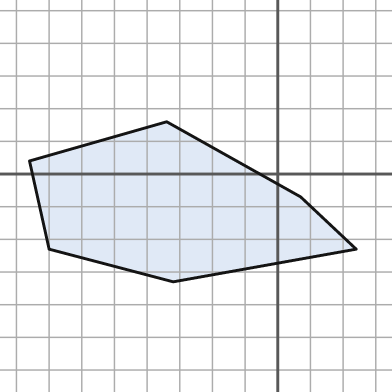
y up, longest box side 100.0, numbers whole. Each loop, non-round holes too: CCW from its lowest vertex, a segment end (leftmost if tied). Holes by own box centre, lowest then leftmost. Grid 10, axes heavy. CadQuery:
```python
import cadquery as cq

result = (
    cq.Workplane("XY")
    .moveTo(-32.0, -33.0)
    .lineTo(24.0, -23.0)
    .lineTo(7.0, -7.0)
    .lineTo(-34.0, 16.0)
    .lineTo(-76.0, 4.0)
    .lineTo(-70.0, -23.0)
    .close()
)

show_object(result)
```